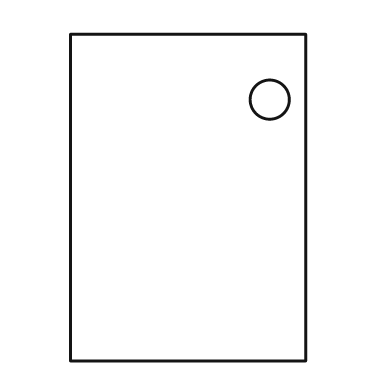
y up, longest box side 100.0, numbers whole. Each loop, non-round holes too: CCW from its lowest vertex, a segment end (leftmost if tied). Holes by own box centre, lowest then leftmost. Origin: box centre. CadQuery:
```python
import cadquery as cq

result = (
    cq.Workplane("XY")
    .moveTo(-36.0, -50.0)
    .lineTo(36.0, -50.0)
    .lineTo(36.0, 50.0)
    .lineTo(-36.0, 50.0)
    .close()
    .moveTo(25.0, 30.0)
    .circle(6.0)
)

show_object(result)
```